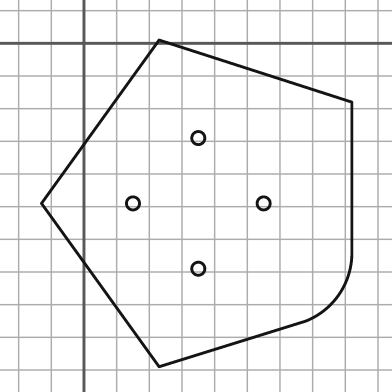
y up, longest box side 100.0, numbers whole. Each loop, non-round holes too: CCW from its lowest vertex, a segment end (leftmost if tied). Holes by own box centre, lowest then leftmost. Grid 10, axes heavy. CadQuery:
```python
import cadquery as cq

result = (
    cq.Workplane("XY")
    .moveTo(23.0, -99.0)
    .lineTo(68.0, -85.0)
    .threePointArc((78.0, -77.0), (82.0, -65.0))
    .lineTo(82.0, -18.0)
    .lineTo(23.0, 1.0)
    .lineTo(-13.0, -49.0)
    .close()
    .moveTo(35.0, -69.0)
    .circle(2.0)
    .moveTo(15.0, -49.0)
    .circle(2.0)
    .moveTo(55.0, -49.0)
    .circle(2.0)
    .moveTo(35.0, -29.0)
    .circle(2.0)
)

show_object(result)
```